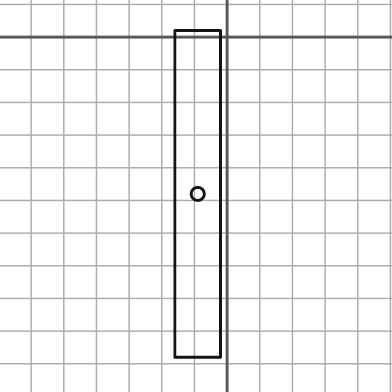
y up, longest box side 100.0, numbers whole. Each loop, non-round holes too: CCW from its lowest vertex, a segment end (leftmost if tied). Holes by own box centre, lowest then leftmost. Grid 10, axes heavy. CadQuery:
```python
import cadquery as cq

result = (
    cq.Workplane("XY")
    .moveTo(-16.0, -98.0)
    .lineTo(-2.0, -98.0)
    .lineTo(-2.0, 2.0)
    .lineTo(-16.0, 2.0)
    .close()
    .moveTo(-9.0, -48.0)
    .circle(2.0)
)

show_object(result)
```